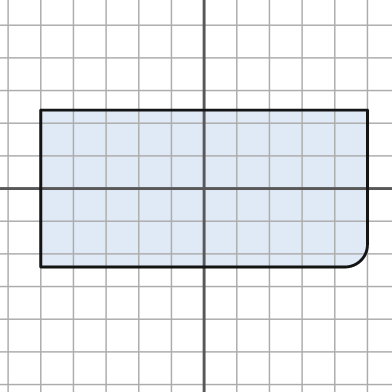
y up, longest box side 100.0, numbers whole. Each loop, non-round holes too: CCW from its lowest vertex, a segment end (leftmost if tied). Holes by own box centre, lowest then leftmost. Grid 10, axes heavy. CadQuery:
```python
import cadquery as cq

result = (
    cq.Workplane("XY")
    .moveTo(-50.0, -24.0)
    .lineTo(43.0, -24.0)
    .threePointArc((48.0, -22.0), (50.0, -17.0))
    .lineTo(50.0, 24.0)
    .lineTo(-50.0, 24.0)
    .close()
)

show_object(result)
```